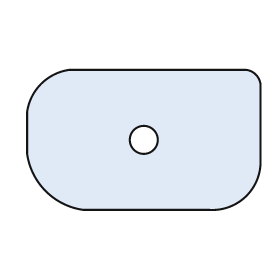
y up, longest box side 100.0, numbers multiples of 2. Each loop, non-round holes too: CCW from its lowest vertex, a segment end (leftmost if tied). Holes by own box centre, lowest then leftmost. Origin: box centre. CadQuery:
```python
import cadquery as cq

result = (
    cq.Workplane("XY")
    .moveTo(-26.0, -30.0)
    .lineTo(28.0, -30.0)
    .threePointArc((44.0, -24.0), (50.0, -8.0))
    .lineTo(50.0, 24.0)
    .threePointArc((48.0, 28.0), (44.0, 30.0))
    .lineTo(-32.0, 30.0)
    .threePointArc((-44.0, 24.0), (-50.0, 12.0))
    .lineTo(-50.0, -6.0)
    .threePointArc((-42.0, -22.0), (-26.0, -30.0))
    .close()
    .moveTo(0.0, 0.0)
    .circle(6.0)
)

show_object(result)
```